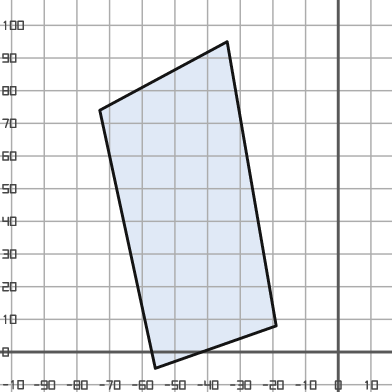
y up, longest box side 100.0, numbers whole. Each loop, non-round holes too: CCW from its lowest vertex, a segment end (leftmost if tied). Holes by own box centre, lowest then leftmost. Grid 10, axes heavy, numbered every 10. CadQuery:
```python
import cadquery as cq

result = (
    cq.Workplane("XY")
    .moveTo(-56.0, -5.0)
    .lineTo(-19.0, 8.0)
    .lineTo(-34.0, 95.0)
    .lineTo(-73.0, 74.0)
    .close()
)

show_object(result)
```